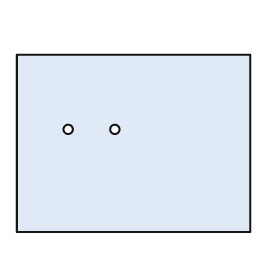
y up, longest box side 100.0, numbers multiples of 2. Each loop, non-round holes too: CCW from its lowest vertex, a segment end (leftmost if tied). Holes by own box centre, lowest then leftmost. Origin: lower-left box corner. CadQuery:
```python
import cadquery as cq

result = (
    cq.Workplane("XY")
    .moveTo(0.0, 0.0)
    .lineTo(100.0, 0.0)
    .lineTo(100.0, 76.0)
    .lineTo(0.0, 76.0)
    .close()
    .moveTo(22.0, 44.0)
    .circle(2.0)
    .moveTo(42.0, 44.0)
    .circle(2.0)
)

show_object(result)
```